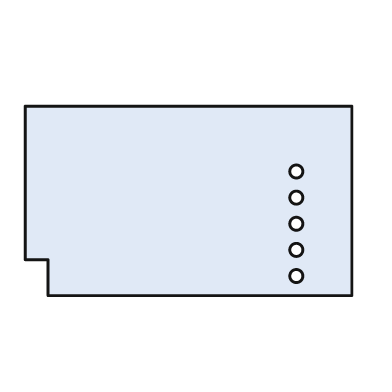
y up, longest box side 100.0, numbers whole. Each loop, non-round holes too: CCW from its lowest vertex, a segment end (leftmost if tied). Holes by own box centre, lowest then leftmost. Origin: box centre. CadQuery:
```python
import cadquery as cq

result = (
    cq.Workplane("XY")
    .moveTo(-43.0, -29.0)
    .lineTo(50.0, -29.0)
    .lineTo(50.0, 29.0)
    .lineTo(-50.0, 29.0)
    .lineTo(-50.0, -18.0)
    .lineTo(-43.0, -18.0)
    .close()
    .moveTo(33.0, -23.0)
    .circle(2.0)
    .moveTo(33.0, -15.0)
    .circle(2.0)
    .moveTo(33.0, -7.0)
    .circle(2.0)
    .moveTo(33.0, 1.0)
    .circle(2.0)
    .moveTo(33.0, 9.0)
    .circle(2.0)
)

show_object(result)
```